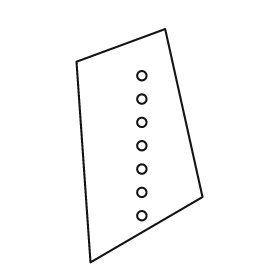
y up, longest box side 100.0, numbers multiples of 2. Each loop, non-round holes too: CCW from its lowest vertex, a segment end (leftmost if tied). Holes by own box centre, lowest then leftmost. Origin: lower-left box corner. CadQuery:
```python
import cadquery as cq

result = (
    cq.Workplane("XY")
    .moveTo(6.0, 0.0)
    .lineTo(54.0, 28.0)
    .lineTo(38.0, 100.0)
    .lineTo(0.0, 86.0)
    .close()
    .moveTo(28.0, 20.0)
    .circle(2.0)
    .moveTo(28.0, 30.0)
    .circle(2.0)
    .moveTo(28.0, 40.0)
    .circle(2.0)
    .moveTo(28.0, 50.0)
    .circle(2.0)
    .moveTo(28.0, 60.0)
    .circle(2.0)
    .moveTo(28.0, 70.0)
    .circle(2.0)
    .moveTo(28.0, 80.0)
    .circle(2.0)
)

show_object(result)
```